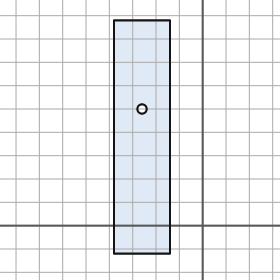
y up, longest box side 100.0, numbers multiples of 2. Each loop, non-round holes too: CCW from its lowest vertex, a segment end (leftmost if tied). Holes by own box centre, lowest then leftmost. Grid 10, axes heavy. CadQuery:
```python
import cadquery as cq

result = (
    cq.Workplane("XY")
    .moveTo(-38.0, -12.0)
    .lineTo(-14.0, -12.0)
    .lineTo(-14.0, 88.0)
    .lineTo(-38.0, 88.0)
    .close()
    .moveTo(-26.0, 50.0)
    .circle(2.0)
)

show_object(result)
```